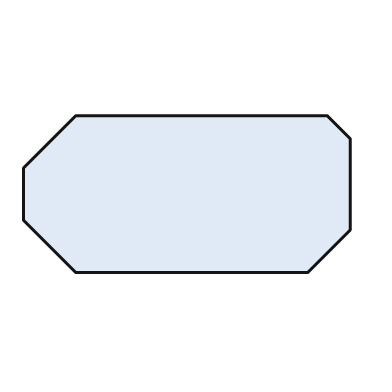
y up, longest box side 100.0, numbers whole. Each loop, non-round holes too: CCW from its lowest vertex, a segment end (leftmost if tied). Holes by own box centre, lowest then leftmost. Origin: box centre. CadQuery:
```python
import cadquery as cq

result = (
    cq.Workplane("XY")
    .moveTo(-34.0, -24.0)
    .lineTo(37.0, -24.0)
    .lineTo(50.0, -11.0)
    .lineTo(50.0, 17.0)
    .lineTo(43.0, 24.0)
    .lineTo(-34.0, 24.0)
    .lineTo(-50.0, 8.0)
    .lineTo(-50.0, -8.0)
    .close()
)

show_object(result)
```